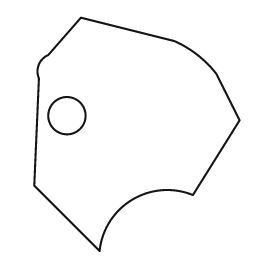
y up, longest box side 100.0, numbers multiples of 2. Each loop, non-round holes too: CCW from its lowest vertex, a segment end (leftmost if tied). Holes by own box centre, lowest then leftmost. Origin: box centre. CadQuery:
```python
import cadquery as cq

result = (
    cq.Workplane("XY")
    .moveTo(-16.0, -50.0)
    .threePointArc((-2.0, -28.0), (24.0, -26.0))
    .lineTo(44.0, 6.0)
    .lineTo(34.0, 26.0)
    .threePointArc((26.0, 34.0), (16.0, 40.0))
    .lineTo(-24.0, 50.0)
    .lineTo(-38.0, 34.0)
    .threePointArc((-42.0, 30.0), (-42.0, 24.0))
    .lineTo(-44.0, -22.0)
    .close()
    .moveTo(-30.0, 8.0)
    .circle(8.0)
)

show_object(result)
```